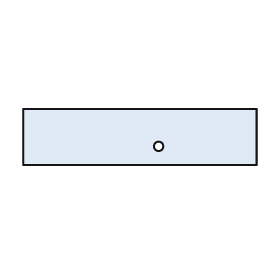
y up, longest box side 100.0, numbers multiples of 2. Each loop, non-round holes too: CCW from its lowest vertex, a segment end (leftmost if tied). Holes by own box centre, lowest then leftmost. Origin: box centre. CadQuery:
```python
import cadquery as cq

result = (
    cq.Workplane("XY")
    .moveTo(-50.0, -12.0)
    .lineTo(50.0, -12.0)
    .lineTo(50.0, 12.0)
    .lineTo(-50.0, 12.0)
    .close()
    .moveTo(8.0, -4.0)
    .circle(2.0)
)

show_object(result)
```